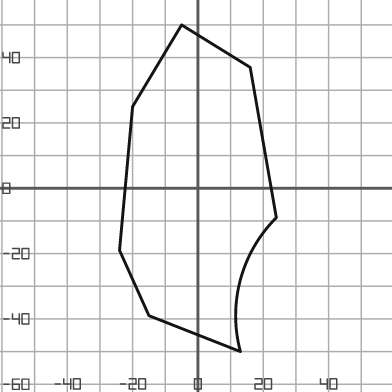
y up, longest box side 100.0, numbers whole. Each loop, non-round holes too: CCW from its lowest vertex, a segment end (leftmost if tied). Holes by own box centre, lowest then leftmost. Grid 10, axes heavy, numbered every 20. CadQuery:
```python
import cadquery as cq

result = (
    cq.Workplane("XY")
    .moveTo(13.0, -50.0)
    .threePointArc((13.0, -28.0), (24.0, -9.0))
    .lineTo(16.0, 37.0)
    .lineTo(-5.0, 50.0)
    .lineTo(-20.0, 25.0)
    .lineTo(-24.0, -19.0)
    .lineTo(-15.0, -39.0)
    .close()
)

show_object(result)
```